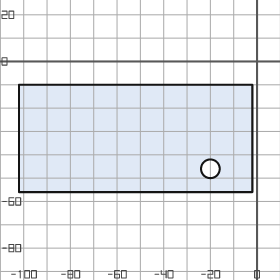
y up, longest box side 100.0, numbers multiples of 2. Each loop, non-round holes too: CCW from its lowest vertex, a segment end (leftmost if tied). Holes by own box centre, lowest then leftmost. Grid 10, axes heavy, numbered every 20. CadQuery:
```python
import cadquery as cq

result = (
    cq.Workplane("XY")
    .moveTo(-102.0, -56.0)
    .lineTo(-2.0, -56.0)
    .lineTo(-2.0, -10.0)
    .lineTo(-102.0, -10.0)
    .close()
    .moveTo(-20.0, -46.0)
    .circle(4.0)
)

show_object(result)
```